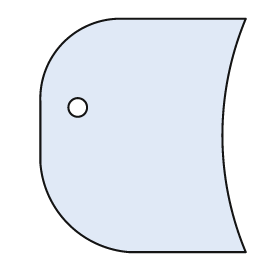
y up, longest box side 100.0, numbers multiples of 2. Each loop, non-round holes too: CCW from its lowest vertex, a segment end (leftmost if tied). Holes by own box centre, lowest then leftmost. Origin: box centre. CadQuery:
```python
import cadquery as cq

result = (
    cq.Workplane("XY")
    .moveTo(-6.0, -50.0)
    .lineTo(44.0, -50.0)
    .threePointArc((34.0, 0.0), (44.0, 50.0))
    .lineTo(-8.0, 50.0)
    .threePointArc((-34.0, 40.0), (-44.0, 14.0))
    .lineTo(-44.0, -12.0)
    .threePointArc((-32.0, -38.0), (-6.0, -50.0))
    .close()
    .moveTo(-28.0, 12.0)
    .circle(4.0)
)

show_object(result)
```